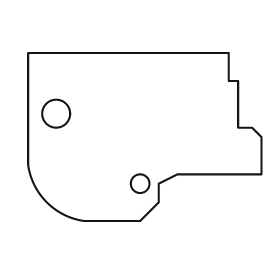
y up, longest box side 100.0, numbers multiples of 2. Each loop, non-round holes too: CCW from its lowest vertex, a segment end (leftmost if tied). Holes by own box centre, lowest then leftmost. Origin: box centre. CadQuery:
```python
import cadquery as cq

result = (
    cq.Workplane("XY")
    .moveTo(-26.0, -36.0)
    .lineTo(-2.0, -36.0)
    .lineTo(6.0, -28.0)
    .lineTo(6.0, -20.0)
    .lineTo(14.0, -16.0)
    .lineTo(50.0, -16.0)
    .lineTo(50.0, 0.0)
    .lineTo(46.0, 4.0)
    .lineTo(40.0, 4.0)
    .lineTo(40.0, 24.0)
    .lineTo(36.0, 24.0)
    .lineTo(36.0, 36.0)
    .lineTo(-50.0, 36.0)
    .lineTo(-50.0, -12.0)
    .threePointArc((-42.0, -28.0), (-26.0, -36.0))
    .close()
    .moveTo(-2.0, -20.0)
    .circle(4.0)
    .moveTo(-38.0, 10.0)
    .circle(6.0)
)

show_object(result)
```